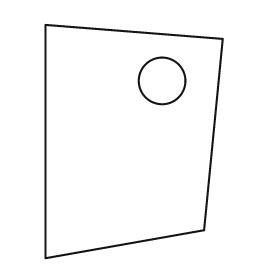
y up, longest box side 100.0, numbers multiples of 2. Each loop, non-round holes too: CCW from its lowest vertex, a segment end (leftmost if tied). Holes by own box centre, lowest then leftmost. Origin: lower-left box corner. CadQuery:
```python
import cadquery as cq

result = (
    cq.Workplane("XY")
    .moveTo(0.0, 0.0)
    .lineTo(68.0, 12.0)
    .lineTo(76.0, 94.0)
    .lineTo(0.0, 100.0)
    .close()
    .moveTo(50.0, 76.0)
    .circle(10.0)
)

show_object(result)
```